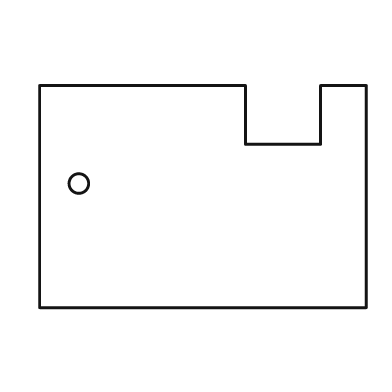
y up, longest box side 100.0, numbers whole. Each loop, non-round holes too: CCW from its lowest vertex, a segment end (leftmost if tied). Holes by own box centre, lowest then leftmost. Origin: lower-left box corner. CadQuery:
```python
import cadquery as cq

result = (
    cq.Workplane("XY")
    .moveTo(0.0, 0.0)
    .lineTo(100.0, 0.0)
    .lineTo(100.0, 68.0)
    .lineTo(86.0, 68.0)
    .lineTo(86.0, 50.0)
    .lineTo(63.0, 50.0)
    .lineTo(63.0, 68.0)
    .lineTo(0.0, 68.0)
    .close()
    .moveTo(12.0, 38.0)
    .circle(3.0)
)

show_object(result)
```